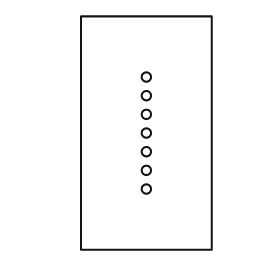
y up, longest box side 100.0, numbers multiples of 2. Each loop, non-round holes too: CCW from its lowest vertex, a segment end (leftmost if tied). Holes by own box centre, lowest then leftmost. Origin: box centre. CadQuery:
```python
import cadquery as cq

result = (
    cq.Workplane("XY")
    .moveTo(-28.0, -50.0)
    .lineTo(28.0, -50.0)
    .lineTo(28.0, 50.0)
    .lineTo(-28.0, 50.0)
    .close()
    .moveTo(0.0, -24.0)
    .circle(2.0)
    .moveTo(0.0, -16.0)
    .circle(2.0)
    .moveTo(0.0, -8.0)
    .circle(2.0)
    .moveTo(0.0, 0.0)
    .circle(2.0)
    .moveTo(0.0, 8.0)
    .circle(2.0)
    .moveTo(0.0, 16.0)
    .circle(2.0)
    .moveTo(0.0, 24.0)
    .circle(2.0)
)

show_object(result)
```